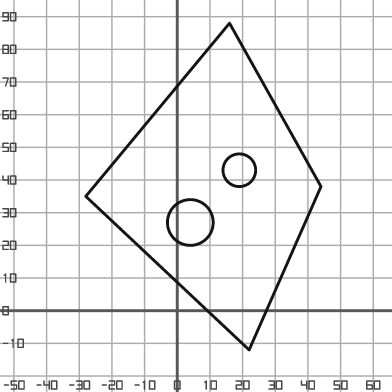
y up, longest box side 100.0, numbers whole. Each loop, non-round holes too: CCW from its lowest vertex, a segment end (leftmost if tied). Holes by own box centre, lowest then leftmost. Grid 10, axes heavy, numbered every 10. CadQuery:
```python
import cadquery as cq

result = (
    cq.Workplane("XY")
    .moveTo(22.0, -12.0)
    .lineTo(44.0, 38.0)
    .lineTo(16.0, 88.0)
    .lineTo(-28.0, 35.0)
    .close()
    .moveTo(4.0, 27.0)
    .circle(7.0)
    .moveTo(19.0, 43.0)
    .circle(5.0)
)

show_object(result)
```